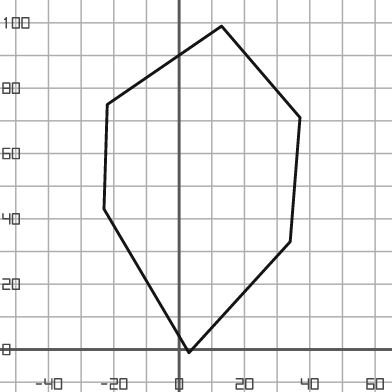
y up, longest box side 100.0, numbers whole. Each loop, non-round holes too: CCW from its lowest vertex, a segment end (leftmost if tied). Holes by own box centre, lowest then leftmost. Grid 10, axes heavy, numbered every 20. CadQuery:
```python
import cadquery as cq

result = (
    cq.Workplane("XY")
    .moveTo(3.0, -1.0)
    .lineTo(34.0, 33.0)
    .lineTo(37.0, 71.0)
    .lineTo(13.0, 99.0)
    .lineTo(-22.0, 75.0)
    .lineTo(-23.0, 43.0)
    .close()
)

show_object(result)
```